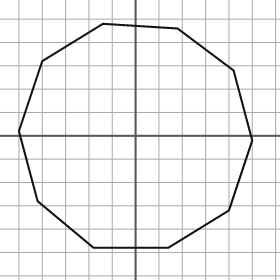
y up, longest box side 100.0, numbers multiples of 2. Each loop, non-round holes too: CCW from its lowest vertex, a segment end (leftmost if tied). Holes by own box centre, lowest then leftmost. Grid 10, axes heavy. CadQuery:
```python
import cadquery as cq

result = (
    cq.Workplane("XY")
    .moveTo(-18.0, -48.0)
    .lineTo(14.0, -48.0)
    .lineTo(40.0, -32.0)
    .lineTo(50.0, -2.0)
    .lineTo(42.0, 28.0)
    .lineTo(18.0, 46.0)
    .lineTo(-14.0, 48.0)
    .lineTo(-40.0, 32.0)
    .lineTo(-50.0, 2.0)
    .lineTo(-42.0, -28.0)
    .close()
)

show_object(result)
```